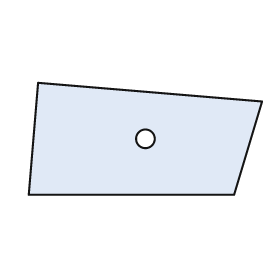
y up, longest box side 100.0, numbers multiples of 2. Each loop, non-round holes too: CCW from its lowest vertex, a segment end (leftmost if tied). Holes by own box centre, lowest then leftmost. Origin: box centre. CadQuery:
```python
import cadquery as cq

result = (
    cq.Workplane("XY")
    .moveTo(-50.0, -24.0)
    .lineTo(38.0, -24.0)
    .lineTo(50.0, 16.0)
    .lineTo(-46.0, 24.0)
    .close()
    .moveTo(0.0, 0.0)
    .circle(4.0)
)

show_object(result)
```